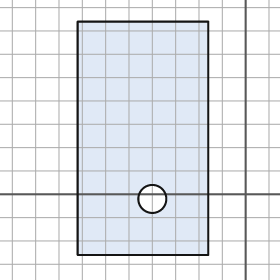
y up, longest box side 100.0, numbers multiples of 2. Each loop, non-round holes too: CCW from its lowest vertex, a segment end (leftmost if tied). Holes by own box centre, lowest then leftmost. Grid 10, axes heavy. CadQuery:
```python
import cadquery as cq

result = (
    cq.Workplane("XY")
    .moveTo(-72.0, -26.0)
    .lineTo(-16.0, -26.0)
    .lineTo(-16.0, 74.0)
    .lineTo(-72.0, 74.0)
    .close()
    .moveTo(-40.0, -2.0)
    .circle(6.0)
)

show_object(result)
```